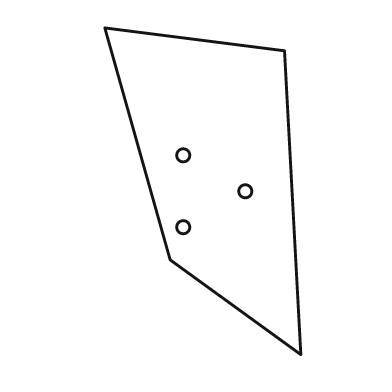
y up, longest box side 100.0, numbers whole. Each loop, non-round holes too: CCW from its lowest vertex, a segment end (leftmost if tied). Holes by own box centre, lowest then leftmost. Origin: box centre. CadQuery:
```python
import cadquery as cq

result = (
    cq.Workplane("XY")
    .moveTo(30.0, -50.0)
    .lineTo(25.0, 43.0)
    .lineTo(-30.0, 50.0)
    .lineTo(-10.0, -21.0)
    .close()
    .moveTo(-6.0, -11.0)
    .circle(2.0)
    .moveTo(13.0, 0.0)
    .circle(2.0)
    .moveTo(-6.0, 11.0)
    .circle(2.0)
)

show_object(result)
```